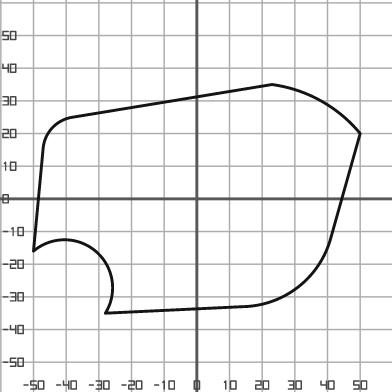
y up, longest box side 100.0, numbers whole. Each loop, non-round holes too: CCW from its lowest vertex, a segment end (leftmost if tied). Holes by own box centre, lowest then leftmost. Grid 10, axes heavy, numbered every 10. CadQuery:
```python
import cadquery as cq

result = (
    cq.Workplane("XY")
    .moveTo(-28.0, -35.0)
    .lineTo(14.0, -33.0)
    .threePointArc((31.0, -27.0), (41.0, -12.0))
    .lineTo(50.0, 20.0)
    .threePointArc((38.0, 30.0), (23.0, 35.0))
    .lineTo(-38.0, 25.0)
    .threePointArc((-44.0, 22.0), (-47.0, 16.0))
    .lineTo(-50.0, -16.0)
    .threePointArc((-31.0, -16.0), (-28.0, -35.0))
    .close()
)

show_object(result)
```